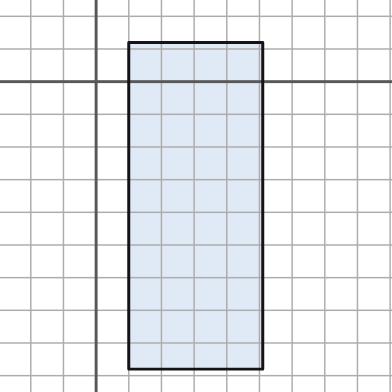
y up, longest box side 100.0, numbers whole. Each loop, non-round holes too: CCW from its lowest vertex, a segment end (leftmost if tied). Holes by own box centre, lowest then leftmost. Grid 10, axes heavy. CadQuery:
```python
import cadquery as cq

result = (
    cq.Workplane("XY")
    .moveTo(10.0, -88.0)
    .lineTo(51.0, -88.0)
    .lineTo(51.0, 12.0)
    .lineTo(10.0, 12.0)
    .close()
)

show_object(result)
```